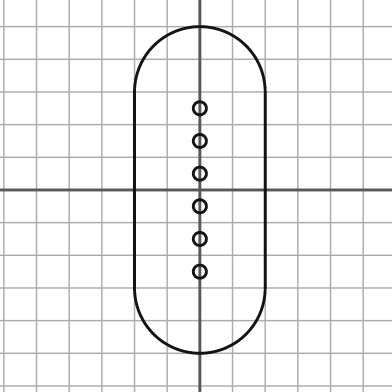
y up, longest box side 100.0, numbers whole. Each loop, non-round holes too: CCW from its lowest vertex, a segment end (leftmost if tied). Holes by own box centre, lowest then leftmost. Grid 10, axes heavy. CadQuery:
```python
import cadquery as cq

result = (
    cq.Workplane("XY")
    .moveTo(-20.0, -30.0)
    .threePointArc((0.0, -50.0), (20.0, -30.0))
    .lineTo(20.0, 30.0)
    .threePointArc((0.0, 50.0), (-20.0, 30.0))
    .close()
    .moveTo(0.0, -25.0)
    .circle(2.0)
    .moveTo(0.0, -15.0)
    .circle(2.0)
    .moveTo(0.0, -5.0)
    .circle(2.0)
    .moveTo(0.0, 5.0)
    .circle(2.0)
    .moveTo(0.0, 15.0)
    .circle(2.0)
    .moveTo(0.0, 25.0)
    .circle(2.0)
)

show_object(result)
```